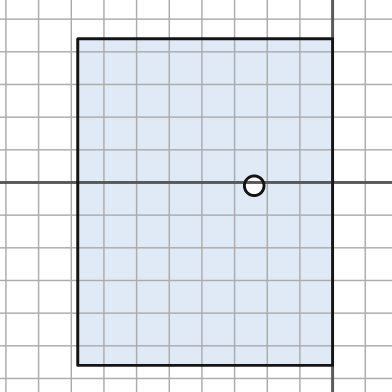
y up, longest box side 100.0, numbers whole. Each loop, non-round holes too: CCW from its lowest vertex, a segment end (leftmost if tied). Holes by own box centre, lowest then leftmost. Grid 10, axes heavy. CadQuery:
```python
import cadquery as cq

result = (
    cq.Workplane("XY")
    .moveTo(-78.0, -56.0)
    .lineTo(0.0, -56.0)
    .lineTo(0.0, 44.0)
    .lineTo(-78.0, 44.0)
    .close()
    .moveTo(-24.0, -1.0)
    .circle(3.0)
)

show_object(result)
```